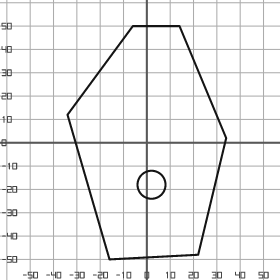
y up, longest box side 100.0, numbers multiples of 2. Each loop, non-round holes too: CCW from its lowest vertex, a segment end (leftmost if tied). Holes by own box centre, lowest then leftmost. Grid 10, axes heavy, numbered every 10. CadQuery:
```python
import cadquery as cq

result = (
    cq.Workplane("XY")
    .moveTo(-16.0, -50.0)
    .lineTo(22.0, -48.0)
    .lineTo(34.0, 2.0)
    .lineTo(14.0, 50.0)
    .lineTo(-6.0, 50.0)
    .lineTo(-34.0, 12.0)
    .close()
    .moveTo(2.0, -18.0)
    .circle(6.0)
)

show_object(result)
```